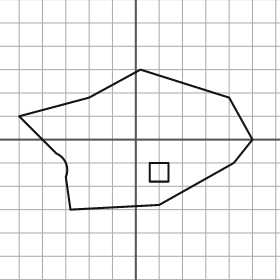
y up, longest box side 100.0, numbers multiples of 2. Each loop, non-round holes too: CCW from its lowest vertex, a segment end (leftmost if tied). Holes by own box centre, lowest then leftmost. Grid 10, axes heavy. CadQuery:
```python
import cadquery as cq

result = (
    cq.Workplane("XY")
    .moveTo(-28.0, -30.0)
    .lineTo(10.0, -28.0)
    .lineTo(42.0, -10.0)
    .lineTo(50.0, 0.0)
    .lineTo(40.0, 18.0)
    .lineTo(2.0, 30.0)
    .lineTo(-20.0, 18.0)
    .lineTo(-50.0, 10.0)
    .lineTo(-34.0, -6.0)
    .threePointArc((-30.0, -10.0), (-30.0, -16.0))
    .close()
    .moveTo(6.0, -18.0)
    .lineTo(14.0, -18.0)
    .lineTo(14.0, -10.0)
    .lineTo(6.0, -10.0)
    .close()
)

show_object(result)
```